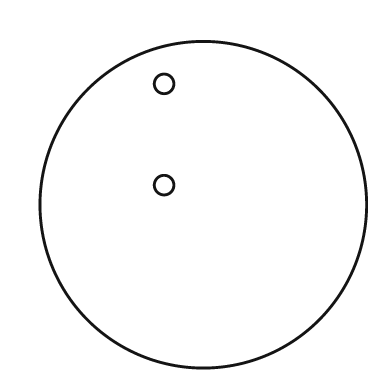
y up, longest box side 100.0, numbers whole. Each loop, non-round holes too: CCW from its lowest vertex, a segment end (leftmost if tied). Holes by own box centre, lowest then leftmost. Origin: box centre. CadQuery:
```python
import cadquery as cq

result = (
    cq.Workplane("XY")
    .moveTo(0.0, 0.0)
    .circle(50.0)
    .moveTo(-12.0, 6.0)
    .circle(3.0)
    .moveTo(-12.0, 37.0)
    .circle(3.0)
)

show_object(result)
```